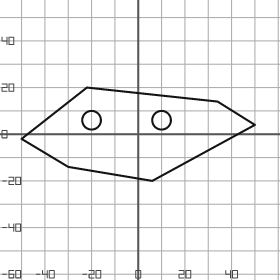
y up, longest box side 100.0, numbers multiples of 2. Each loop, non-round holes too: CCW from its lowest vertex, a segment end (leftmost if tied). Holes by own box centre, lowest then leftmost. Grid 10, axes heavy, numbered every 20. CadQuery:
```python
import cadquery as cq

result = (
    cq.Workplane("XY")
    .moveTo(6.0, -20.0)
    .lineTo(50.0, 4.0)
    .lineTo(34.0, 14.0)
    .lineTo(-22.0, 20.0)
    .lineTo(-50.0, -2.0)
    .lineTo(-30.0, -14.0)
    .close()
    .moveTo(-20.0, 6.0)
    .circle(4.0)
    .moveTo(10.0, 6.0)
    .circle(4.0)
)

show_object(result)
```